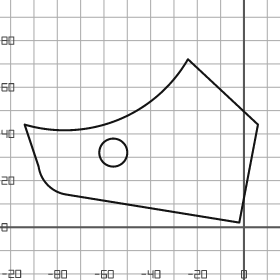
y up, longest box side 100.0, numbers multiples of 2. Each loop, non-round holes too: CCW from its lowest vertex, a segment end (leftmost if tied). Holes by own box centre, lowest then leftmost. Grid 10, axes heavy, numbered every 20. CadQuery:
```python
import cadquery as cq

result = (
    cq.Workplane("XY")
    .moveTo(-2.0, 2.0)
    .lineTo(6.0, 44.0)
    .lineTo(-24.0, 72.0)
    .threePointArc((-54.0, 46.0), (-94.0, 44.0))
    .lineTo(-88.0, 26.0)
    .threePointArc((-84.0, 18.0), (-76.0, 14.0))
    .close()
    .moveTo(-56.0, 32.0)
    .circle(6.0)
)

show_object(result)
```